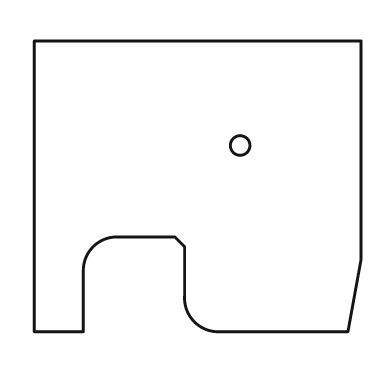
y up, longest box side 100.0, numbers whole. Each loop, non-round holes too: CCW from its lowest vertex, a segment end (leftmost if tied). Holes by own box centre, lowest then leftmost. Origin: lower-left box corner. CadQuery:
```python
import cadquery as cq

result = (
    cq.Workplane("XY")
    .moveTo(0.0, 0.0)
    .lineTo(15.0, 0.0)
    .lineTo(15.0, 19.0)
    .threePointArc((18.0, 26.0), (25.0, 29.0))
    .lineTo(43.0, 29.0)
    .lineTo(46.0, 26.0)
    .lineTo(46.0, 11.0)
    .threePointArc((49.0, 3.0), (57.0, 0.0))
    .lineTo(96.0, 0.0)
    .lineTo(100.0, 22.0)
    .lineTo(100.0, 89.0)
    .lineTo(0.0, 89.0)
    .close()
    .moveTo(63.0, 57.0)
    .circle(3.0)
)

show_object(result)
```